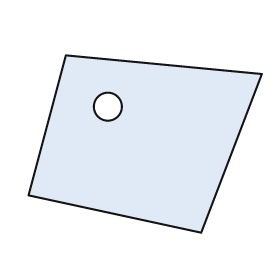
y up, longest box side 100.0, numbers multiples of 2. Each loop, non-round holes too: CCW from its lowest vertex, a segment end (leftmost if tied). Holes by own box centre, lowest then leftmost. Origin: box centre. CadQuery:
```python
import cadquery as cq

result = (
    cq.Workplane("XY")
    .moveTo(24.0, -38.0)
    .lineTo(50.0, 30.0)
    .lineTo(-34.0, 38.0)
    .lineTo(-50.0, -22.0)
    .close()
    .moveTo(-16.0, 16.0)
    .circle(6.0)
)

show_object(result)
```